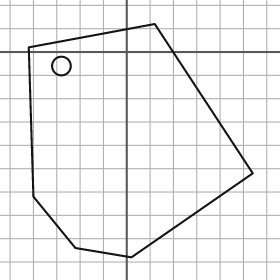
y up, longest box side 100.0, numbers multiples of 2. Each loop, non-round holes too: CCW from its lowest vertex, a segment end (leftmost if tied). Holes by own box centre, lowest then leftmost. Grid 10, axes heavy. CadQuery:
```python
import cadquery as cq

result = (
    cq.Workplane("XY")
    .moveTo(2.0, -88.0)
    .lineTo(54.0, -52.0)
    .lineTo(12.0, 12.0)
    .lineTo(-42.0, 2.0)
    .lineTo(-40.0, -62.0)
    .lineTo(-22.0, -84.0)
    .close()
    .moveTo(-28.0, -6.0)
    .circle(4.0)
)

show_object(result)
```